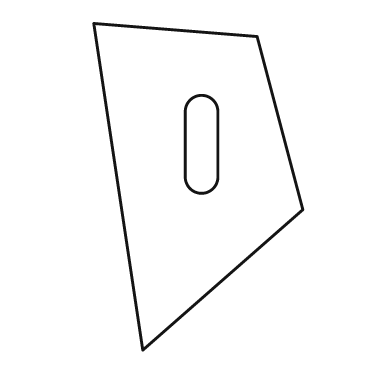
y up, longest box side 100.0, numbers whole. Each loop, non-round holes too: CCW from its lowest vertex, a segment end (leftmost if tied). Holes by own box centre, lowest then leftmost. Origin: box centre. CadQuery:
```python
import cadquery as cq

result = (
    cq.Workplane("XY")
    .moveTo(-17.0, -50.0)
    .lineTo(32.0, -7.0)
    .lineTo(18.0, 46.0)
    .lineTo(-32.0, 50.0)
    .close()
    .moveTo(-4.0, 3.0)
    .threePointArc((1.0, -2.0), (6.0, 3.0))
    .lineTo(6.0, 23.0)
    .threePointArc((1.0, 28.0), (-4.0, 23.0))
    .close()
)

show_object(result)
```